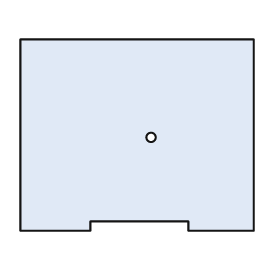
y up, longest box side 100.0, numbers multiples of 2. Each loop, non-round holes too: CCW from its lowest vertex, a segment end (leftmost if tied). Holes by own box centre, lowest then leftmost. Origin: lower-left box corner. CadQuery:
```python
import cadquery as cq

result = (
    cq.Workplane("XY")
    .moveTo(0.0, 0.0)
    .lineTo(30.0, 0.0)
    .lineTo(30.0, 4.0)
    .lineTo(72.0, 4.0)
    .lineTo(72.0, 0.0)
    .lineTo(100.0, 0.0)
    .lineTo(100.0, 82.0)
    .lineTo(0.0, 82.0)
    .close()
    .moveTo(56.0, 40.0)
    .circle(2.0)
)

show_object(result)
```